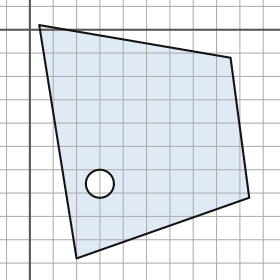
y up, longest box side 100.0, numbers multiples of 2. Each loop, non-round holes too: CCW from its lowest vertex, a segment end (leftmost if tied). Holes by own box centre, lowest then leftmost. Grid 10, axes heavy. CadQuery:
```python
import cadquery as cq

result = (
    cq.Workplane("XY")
    .moveTo(20.0, -98.0)
    .lineTo(94.0, -72.0)
    .lineTo(86.0, -12.0)
    .lineTo(4.0, 2.0)
    .close()
    .moveTo(30.0, -66.0)
    .circle(6.0)
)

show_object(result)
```